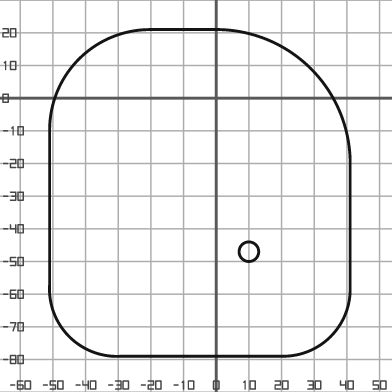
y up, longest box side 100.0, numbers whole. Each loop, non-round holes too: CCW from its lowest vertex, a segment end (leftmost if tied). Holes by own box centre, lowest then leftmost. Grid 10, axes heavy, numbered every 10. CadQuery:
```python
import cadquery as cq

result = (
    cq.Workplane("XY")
    .moveTo(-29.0, -79.0)
    .lineTo(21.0, -79.0)
    .threePointArc((35.0, -73.0), (41.0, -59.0))
    .lineTo(41.0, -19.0)
    .threePointArc((29.0, 9.0), (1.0, 21.0))
    .lineTo(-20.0, 21.0)
    .threePointArc((-42.0, 12.0), (-51.0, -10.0))
    .lineTo(-51.0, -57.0)
    .threePointArc((-45.0, -73.0), (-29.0, -79.0))
    .close()
    .moveTo(10.0, -47.0)
    .circle(3.0)
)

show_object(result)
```